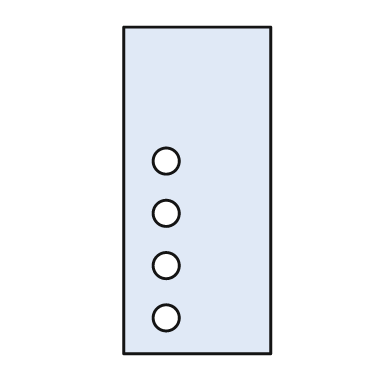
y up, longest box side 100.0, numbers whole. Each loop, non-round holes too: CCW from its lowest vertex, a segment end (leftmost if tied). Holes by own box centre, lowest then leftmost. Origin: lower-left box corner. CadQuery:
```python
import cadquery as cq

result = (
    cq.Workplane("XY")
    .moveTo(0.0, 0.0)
    .lineTo(45.0, 0.0)
    .lineTo(45.0, 100.0)
    .lineTo(0.0, 100.0)
    .close()
    .moveTo(13.0, 11.0)
    .circle(4.0)
    .moveTo(13.0, 27.0)
    .circle(4.0)
    .moveTo(13.0, 43.0)
    .circle(4.0)
    .moveTo(13.0, 59.0)
    .circle(4.0)
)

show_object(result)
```